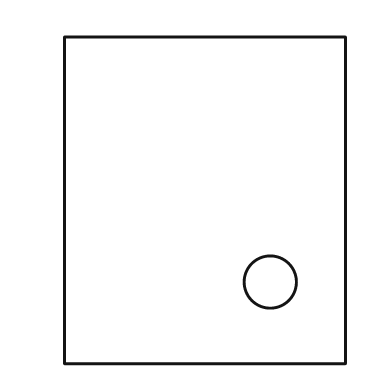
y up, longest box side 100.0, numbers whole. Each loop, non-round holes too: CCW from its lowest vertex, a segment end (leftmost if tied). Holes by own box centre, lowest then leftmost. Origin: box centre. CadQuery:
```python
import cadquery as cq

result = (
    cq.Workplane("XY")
    .moveTo(-43.0, -50.0)
    .lineTo(43.0, -50.0)
    .lineTo(43.0, 50.0)
    .lineTo(-43.0, 50.0)
    .close()
    .moveTo(20.0, -25.0)
    .circle(8.0)
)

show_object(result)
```